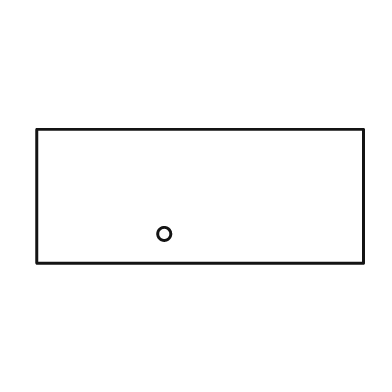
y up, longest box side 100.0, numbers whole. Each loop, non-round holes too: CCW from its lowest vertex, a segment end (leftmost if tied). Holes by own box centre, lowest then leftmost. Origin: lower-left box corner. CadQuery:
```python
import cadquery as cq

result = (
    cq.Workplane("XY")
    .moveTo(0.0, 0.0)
    .lineTo(100.0, 0.0)
    .lineTo(100.0, 41.0)
    .lineTo(0.0, 41.0)
    .close()
    .moveTo(39.0, 9.0)
    .circle(2.0)
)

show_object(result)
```